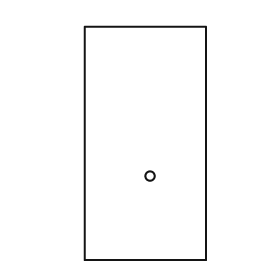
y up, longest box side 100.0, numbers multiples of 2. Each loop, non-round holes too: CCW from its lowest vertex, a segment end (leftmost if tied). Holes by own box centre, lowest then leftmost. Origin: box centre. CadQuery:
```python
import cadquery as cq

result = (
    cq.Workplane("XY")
    .moveTo(-26.0, -50.0)
    .lineTo(26.0, -50.0)
    .lineTo(26.0, 50.0)
    .lineTo(-26.0, 50.0)
    .close()
    .moveTo(2.0, -14.0)
    .circle(2.0)
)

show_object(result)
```